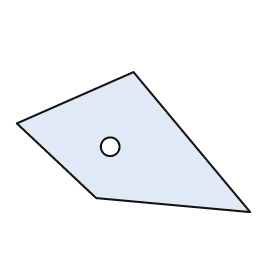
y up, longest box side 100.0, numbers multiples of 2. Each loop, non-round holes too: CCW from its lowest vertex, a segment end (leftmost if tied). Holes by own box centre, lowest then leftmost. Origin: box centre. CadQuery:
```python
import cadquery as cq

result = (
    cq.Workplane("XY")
    .moveTo(50.0, -30.0)
    .lineTo(0.0, 30.0)
    .lineTo(-50.0, 8.0)
    .lineTo(-16.0, -24.0)
    .close()
    .moveTo(-10.0, -2.0)
    .circle(4.0)
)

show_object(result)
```